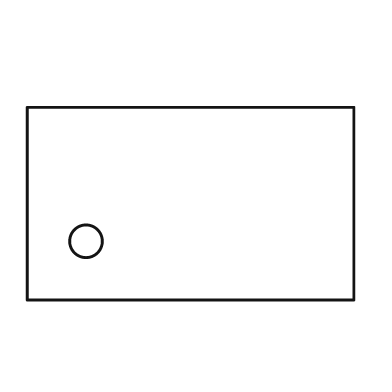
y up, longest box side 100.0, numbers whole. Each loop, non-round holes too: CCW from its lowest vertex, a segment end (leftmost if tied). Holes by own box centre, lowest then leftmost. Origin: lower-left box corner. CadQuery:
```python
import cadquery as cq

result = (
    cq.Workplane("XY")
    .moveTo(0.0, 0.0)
    .lineTo(100.0, 0.0)
    .lineTo(100.0, 59.0)
    .lineTo(0.0, 59.0)
    .close()
    .moveTo(18.0, 18.0)
    .circle(5.0)
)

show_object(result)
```